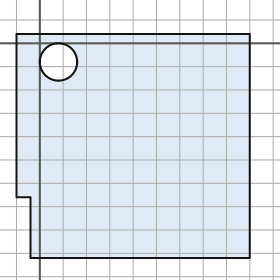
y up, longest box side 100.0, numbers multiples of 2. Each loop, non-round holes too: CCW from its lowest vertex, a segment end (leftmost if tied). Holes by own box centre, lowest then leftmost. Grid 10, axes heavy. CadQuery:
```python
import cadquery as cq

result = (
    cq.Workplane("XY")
    .moveTo(-4.0, -92.0)
    .lineTo(90.0, -92.0)
    .lineTo(90.0, 4.0)
    .lineTo(-10.0, 4.0)
    .lineTo(-10.0, -66.0)
    .lineTo(-4.0, -66.0)
    .close()
    .moveTo(8.0, -8.0)
    .circle(8.0)
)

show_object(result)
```